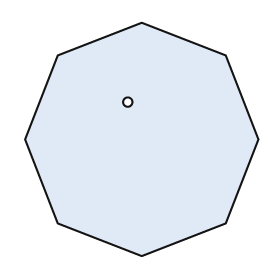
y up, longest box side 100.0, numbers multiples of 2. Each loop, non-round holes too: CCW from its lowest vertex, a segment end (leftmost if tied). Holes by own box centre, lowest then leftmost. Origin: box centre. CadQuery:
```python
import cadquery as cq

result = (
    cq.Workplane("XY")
    .moveTo(0.0, -50.0)
    .lineTo(36.0, -36.0)
    .lineTo(50.0, 0.0)
    .lineTo(36.0, 36.0)
    .lineTo(0.0, 50.0)
    .lineTo(-36.0, 36.0)
    .lineTo(-50.0, 0.0)
    .lineTo(-36.0, -36.0)
    .close()
    .moveTo(-6.0, 16.0)
    .circle(2.0)
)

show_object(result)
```